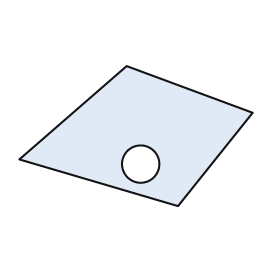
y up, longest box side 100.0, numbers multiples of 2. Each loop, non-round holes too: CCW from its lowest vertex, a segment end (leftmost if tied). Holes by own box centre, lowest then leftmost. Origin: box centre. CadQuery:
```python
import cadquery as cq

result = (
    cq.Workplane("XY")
    .moveTo(18.0, -30.0)
    .lineTo(50.0, 10.0)
    .lineTo(-4.0, 30.0)
    .lineTo(-50.0, -10.0)
    .close()
    .moveTo(2.0, -12.0)
    .circle(8.0)
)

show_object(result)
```